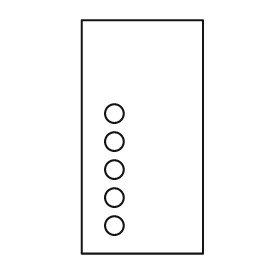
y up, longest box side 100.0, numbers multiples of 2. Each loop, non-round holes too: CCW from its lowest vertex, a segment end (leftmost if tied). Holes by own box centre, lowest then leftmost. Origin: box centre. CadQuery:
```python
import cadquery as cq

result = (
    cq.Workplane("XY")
    .moveTo(-26.0, -50.0)
    .lineTo(26.0, -50.0)
    .lineTo(26.0, 50.0)
    .lineTo(-26.0, 50.0)
    .close()
    .moveTo(-12.0, -38.0)
    .circle(4.0)
    .moveTo(-12.0, -26.0)
    .circle(4.0)
    .moveTo(-12.0, -14.0)
    .circle(4.0)
    .moveTo(-12.0, -2.0)
    .circle(4.0)
    .moveTo(-12.0, 10.0)
    .circle(4.0)
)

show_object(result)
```